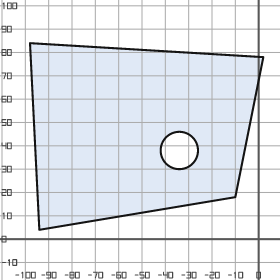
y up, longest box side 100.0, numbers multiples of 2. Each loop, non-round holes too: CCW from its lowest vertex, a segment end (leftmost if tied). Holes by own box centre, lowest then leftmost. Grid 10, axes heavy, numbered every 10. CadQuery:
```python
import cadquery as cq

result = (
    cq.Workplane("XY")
    .moveTo(-94.0, 4.0)
    .lineTo(-10.0, 18.0)
    .lineTo(2.0, 78.0)
    .lineTo(-98.0, 84.0)
    .close()
    .moveTo(-34.0, 38.0)
    .circle(8.0)
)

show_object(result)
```